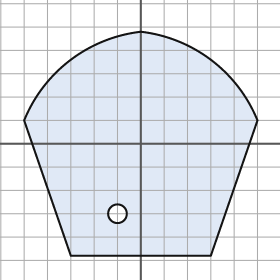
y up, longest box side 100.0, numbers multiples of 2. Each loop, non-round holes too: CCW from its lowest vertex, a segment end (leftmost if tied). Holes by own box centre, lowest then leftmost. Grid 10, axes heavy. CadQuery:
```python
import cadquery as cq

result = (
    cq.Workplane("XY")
    .moveTo(-30.0, -48.0)
    .lineTo(30.0, -48.0)
    .lineTo(50.0, 10.0)
    .threePointArc((30.0, 36.0), (0.0, 48.0))
    .threePointArc((-30.0, 36.0), (-50.0, 10.0))
    .close()
    .moveTo(-10.0, -30.0)
    .circle(4.0)
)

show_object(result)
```